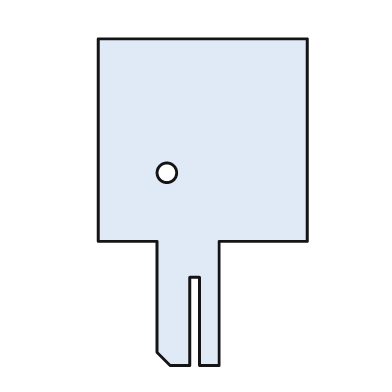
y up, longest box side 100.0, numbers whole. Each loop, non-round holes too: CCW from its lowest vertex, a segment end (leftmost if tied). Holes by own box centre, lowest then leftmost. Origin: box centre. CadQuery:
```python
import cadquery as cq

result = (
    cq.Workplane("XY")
    .moveTo(-10.0, -50.0)
    .lineTo(-4.0, -50.0)
    .lineTo(-4.0, -23.0)
    .lineTo(-1.0, -23.0)
    .lineTo(-1.0, -50.0)
    .lineTo(5.0, -50.0)
    .lineTo(5.0, -12.0)
    .lineTo(32.0, -12.0)
    .lineTo(32.0, 50.0)
    .lineTo(-32.0, 50.0)
    .lineTo(-32.0, -12.0)
    .lineTo(-14.0, -12.0)
    .lineTo(-14.0, -46.0)
    .close()
    .moveTo(-11.0, 9.0)
    .circle(3.0)
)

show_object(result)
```